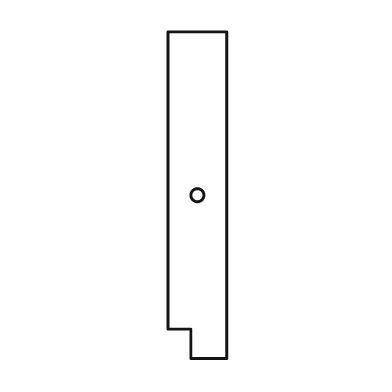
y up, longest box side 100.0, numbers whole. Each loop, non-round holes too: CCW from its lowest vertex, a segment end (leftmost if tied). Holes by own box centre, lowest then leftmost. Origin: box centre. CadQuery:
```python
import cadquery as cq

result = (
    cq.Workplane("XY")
    .moveTo(-2.0, -50.0)
    .lineTo(9.0, -50.0)
    .lineTo(9.0, 50.0)
    .lineTo(-9.0, 50.0)
    .lineTo(-9.0, -41.0)
    .lineTo(-2.0, -41.0)
    .close()
    .moveTo(0.0, 0.0)
    .circle(2.0)
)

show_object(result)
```